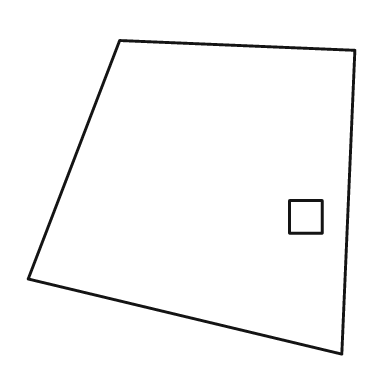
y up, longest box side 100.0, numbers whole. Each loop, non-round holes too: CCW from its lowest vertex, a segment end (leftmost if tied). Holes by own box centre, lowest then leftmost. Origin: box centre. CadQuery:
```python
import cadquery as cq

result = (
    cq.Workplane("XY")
    .moveTo(46.0, -48.0)
    .lineTo(50.0, 45.0)
    .lineTo(-22.0, 48.0)
    .lineTo(-50.0, -25.0)
    .close()
    .moveTo(30.0, -11.0)
    .lineTo(40.0, -11.0)
    .lineTo(40.0, -1.0)
    .lineTo(30.0, -1.0)
    .close()
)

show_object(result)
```